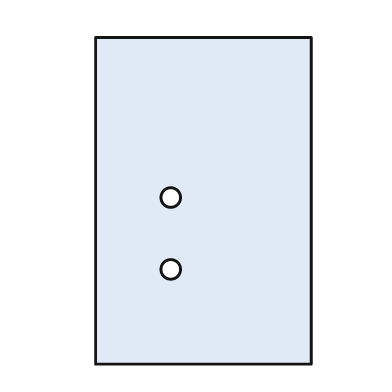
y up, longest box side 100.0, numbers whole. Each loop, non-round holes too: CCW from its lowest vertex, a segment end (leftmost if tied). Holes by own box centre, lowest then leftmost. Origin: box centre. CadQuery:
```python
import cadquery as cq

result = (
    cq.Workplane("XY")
    .moveTo(-33.0, -50.0)
    .lineTo(33.0, -50.0)
    .lineTo(33.0, 50.0)
    .lineTo(-33.0, 50.0)
    .close()
    .moveTo(-10.0, -21.0)
    .circle(3.0)
    .moveTo(-10.0, 1.0)
    .circle(3.0)
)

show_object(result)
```